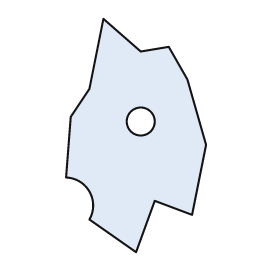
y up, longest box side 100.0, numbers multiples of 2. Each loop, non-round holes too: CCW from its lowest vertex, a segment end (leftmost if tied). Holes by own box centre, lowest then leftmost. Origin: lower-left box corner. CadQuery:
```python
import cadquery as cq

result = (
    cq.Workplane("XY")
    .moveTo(30.0, 0.0)
    .lineTo(38.0, 22.0)
    .lineTo(54.0, 16.0)
    .lineTo(60.0, 46.0)
    .lineTo(52.0, 74.0)
    .lineTo(44.0, 88.0)
    .lineTo(32.0, 86.0)
    .lineTo(16.0, 100.0)
    .lineTo(10.0, 70.0)
    .lineTo(2.0, 58.0)
    .lineTo(0.0, 32.0)
    .threePointArc((10.0, 26.0), (10.0, 14.0))
    .close()
    .moveTo(32.0, 56.0)
    .circle(6.0)
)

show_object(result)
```